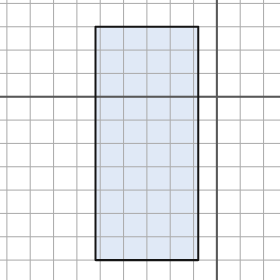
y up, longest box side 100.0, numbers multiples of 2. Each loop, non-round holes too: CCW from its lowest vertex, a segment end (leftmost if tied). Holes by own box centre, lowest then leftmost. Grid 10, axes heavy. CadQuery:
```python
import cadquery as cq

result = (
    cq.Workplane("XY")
    .moveTo(-52.0, -70.0)
    .lineTo(-8.0, -70.0)
    .lineTo(-8.0, 30.0)
    .lineTo(-52.0, 30.0)
    .close()
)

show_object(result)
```